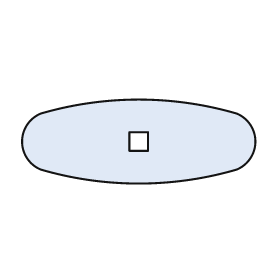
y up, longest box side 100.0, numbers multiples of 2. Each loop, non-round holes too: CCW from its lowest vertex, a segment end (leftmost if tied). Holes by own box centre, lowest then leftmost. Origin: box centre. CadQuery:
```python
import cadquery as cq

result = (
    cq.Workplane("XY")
    .moveTo(-42.0, -12.0)
    .threePointArc((0.0, -18.0), (42.0, -12.0))
    .threePointArc((50.0, 0.0), (42.0, 12.0))
    .threePointArc((0.0, 18.0), (-42.0, 12.0))
    .threePointArc((-50.0, 0.0), (-42.0, -12.0))
    .close()
    .moveTo(-4.0, -4.0)
    .lineTo(4.0, -4.0)
    .lineTo(4.0, 4.0)
    .lineTo(-4.0, 4.0)
    .close()
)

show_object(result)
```